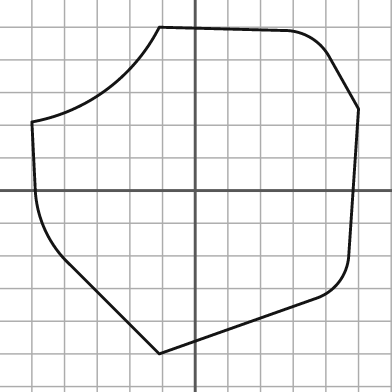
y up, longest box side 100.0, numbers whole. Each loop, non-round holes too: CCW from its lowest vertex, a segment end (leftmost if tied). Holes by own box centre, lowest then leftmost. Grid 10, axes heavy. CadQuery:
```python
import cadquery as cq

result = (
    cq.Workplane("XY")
    .moveTo(-11.0, -50.0)
    .lineTo(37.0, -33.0)
    .threePointArc((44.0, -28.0), (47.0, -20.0))
    .lineTo(50.0, 25.0)
    .lineTo(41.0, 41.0)
    .threePointArc((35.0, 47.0), (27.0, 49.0))
    .lineTo(-11.0, 50.0)
    .threePointArc((-27.0, 31.0), (-50.0, 21.0))
    .lineTo(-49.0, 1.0)
    .threePointArc((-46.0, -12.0), (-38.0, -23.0))
    .close()
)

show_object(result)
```